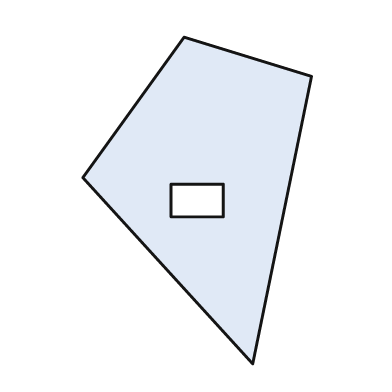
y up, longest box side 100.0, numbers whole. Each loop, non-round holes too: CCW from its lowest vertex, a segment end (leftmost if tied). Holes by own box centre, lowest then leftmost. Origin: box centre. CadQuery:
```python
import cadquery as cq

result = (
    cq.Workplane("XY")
    .moveTo(17.0, -50.0)
    .lineTo(35.0, 38.0)
    .lineTo(-4.0, 50.0)
    .lineTo(-35.0, 7.0)
    .close()
    .moveTo(-8.0, -5.0)
    .lineTo(8.0, -5.0)
    .lineTo(8.0, 5.0)
    .lineTo(-8.0, 5.0)
    .close()
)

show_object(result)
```